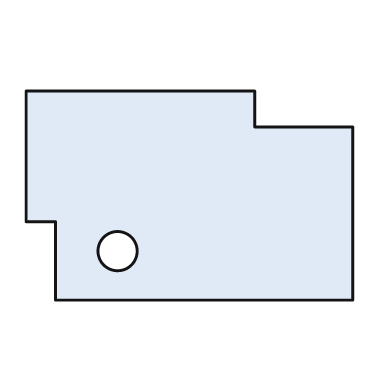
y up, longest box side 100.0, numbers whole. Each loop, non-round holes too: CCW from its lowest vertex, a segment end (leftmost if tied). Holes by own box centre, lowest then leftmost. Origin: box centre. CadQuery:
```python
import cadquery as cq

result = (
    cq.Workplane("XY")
    .moveTo(-41.0, -32.0)
    .lineTo(50.0, -32.0)
    .lineTo(50.0, 21.0)
    .lineTo(20.0, 21.0)
    .lineTo(20.0, 32.0)
    .lineTo(-50.0, 32.0)
    .lineTo(-50.0, -8.0)
    .lineTo(-41.0, -8.0)
    .close()
    .moveTo(-22.0, -17.0)
    .circle(6.0)
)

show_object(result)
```